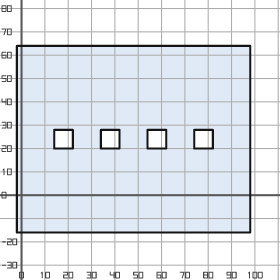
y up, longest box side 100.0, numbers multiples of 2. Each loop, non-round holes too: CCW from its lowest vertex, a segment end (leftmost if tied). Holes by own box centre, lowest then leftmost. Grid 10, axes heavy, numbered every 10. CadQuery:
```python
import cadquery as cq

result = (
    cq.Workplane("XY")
    .moveTo(-2.0, -16.0)
    .lineTo(98.0, -16.0)
    .lineTo(98.0, 64.0)
    .lineTo(-2.0, 64.0)
    .close()
    .moveTo(14.0, 20.0)
    .lineTo(22.0, 20.0)
    .lineTo(22.0, 28.0)
    .lineTo(14.0, 28.0)
    .close()
    .moveTo(34.0, 20.0)
    .lineTo(42.0, 20.0)
    .lineTo(42.0, 28.0)
    .lineTo(34.0, 28.0)
    .close()
    .moveTo(54.0, 20.0)
    .lineTo(62.0, 20.0)
    .lineTo(62.0, 28.0)
    .lineTo(54.0, 28.0)
    .close()
    .moveTo(74.0, 20.0)
    .lineTo(82.0, 20.0)
    .lineTo(82.0, 28.0)
    .lineTo(74.0, 28.0)
    .close()
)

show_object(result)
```